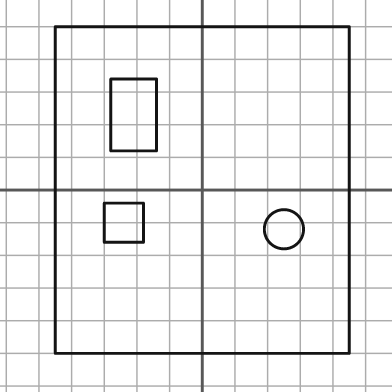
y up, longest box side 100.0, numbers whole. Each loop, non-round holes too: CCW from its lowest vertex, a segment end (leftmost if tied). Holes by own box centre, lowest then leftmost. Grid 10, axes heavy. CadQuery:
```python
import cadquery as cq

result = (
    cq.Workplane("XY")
    .moveTo(-45.0, -50.0)
    .lineTo(45.0, -50.0)
    .lineTo(45.0, 50.0)
    .lineTo(-45.0, 50.0)
    .close()
    .moveTo(25.0, -12.0)
    .circle(6.0)
    .moveTo(-30.0, -16.0)
    .lineTo(-18.0, -16.0)
    .lineTo(-18.0, -4.0)
    .lineTo(-30.0, -4.0)
    .close()
    .moveTo(-28.0, 12.0)
    .lineTo(-14.0, 12.0)
    .lineTo(-14.0, 34.0)
    .lineTo(-28.0, 34.0)
    .close()
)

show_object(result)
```